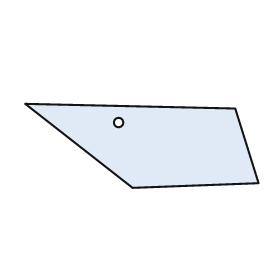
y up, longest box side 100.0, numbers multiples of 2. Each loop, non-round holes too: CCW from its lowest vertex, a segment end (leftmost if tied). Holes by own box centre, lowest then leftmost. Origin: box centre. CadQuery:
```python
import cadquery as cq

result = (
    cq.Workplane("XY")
    .moveTo(-4.0, -18.0)
    .lineTo(50.0, -16.0)
    .lineTo(40.0, 16.0)
    .lineTo(-50.0, 18.0)
    .close()
    .moveTo(-10.0, 10.0)
    .circle(2.0)
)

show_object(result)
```